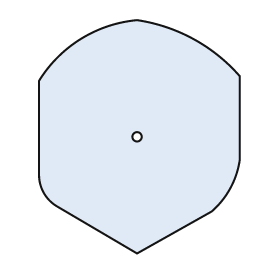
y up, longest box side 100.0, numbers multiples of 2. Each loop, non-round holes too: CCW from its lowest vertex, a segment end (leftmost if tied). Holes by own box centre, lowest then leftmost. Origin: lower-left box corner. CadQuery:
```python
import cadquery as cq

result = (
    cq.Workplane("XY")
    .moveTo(42.0, 0.0)
    .lineTo(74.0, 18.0)
    .threePointArc((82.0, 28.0), (86.0, 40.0))
    .lineTo(86.0, 76.0)
    .threePointArc((66.0, 92.0), (42.0, 100.0))
    .threePointArc((18.0, 92.0), (0.0, 74.0))
    .lineTo(0.0, 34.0)
    .threePointArc((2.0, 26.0), (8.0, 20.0))
    .close()
    .moveTo(42.0, 50.0)
    .circle(2.0)
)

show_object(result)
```